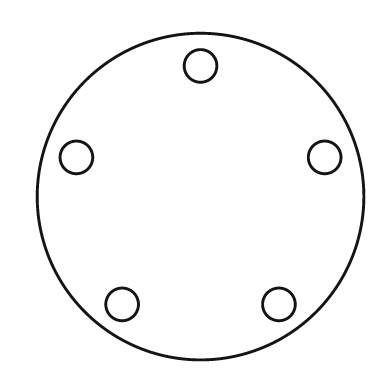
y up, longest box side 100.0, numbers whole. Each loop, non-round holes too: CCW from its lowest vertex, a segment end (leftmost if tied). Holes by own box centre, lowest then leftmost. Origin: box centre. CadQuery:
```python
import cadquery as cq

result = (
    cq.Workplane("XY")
    .moveTo(0.0, 0.0)
    .circle(50.0)
    .moveTo(-24.0, -33.0)
    .circle(5.0)
    .moveTo(24.0, -33.0)
    .circle(5.0)
    .moveTo(-38.0, 12.0)
    .circle(5.0)
    .moveTo(38.0, 12.0)
    .circle(5.0)
    .moveTo(0.0, 40.0)
    .circle(5.0)
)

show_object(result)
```